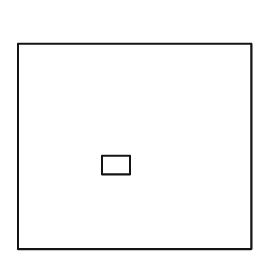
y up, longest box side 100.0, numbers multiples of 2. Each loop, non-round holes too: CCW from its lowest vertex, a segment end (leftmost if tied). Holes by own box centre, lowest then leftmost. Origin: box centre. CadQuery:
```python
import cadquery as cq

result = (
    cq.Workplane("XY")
    .moveTo(-50.0, -44.0)
    .lineTo(50.0, -44.0)
    .lineTo(50.0, 44.0)
    .lineTo(-50.0, 44.0)
    .close()
    .moveTo(-14.0, -12.0)
    .lineTo(-2.0, -12.0)
    .lineTo(-2.0, -4.0)
    .lineTo(-14.0, -4.0)
    .close()
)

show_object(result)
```